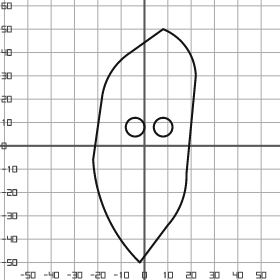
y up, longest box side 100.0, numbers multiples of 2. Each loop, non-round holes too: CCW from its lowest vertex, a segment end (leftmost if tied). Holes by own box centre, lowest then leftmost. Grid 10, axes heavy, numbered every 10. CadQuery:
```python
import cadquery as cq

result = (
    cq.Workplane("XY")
    .moveTo(-2.0, -50.0)
    .lineTo(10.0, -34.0)
    .threePointArc((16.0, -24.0), (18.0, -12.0))
    .lineTo(22.0, 30.0)
    .threePointArc((18.0, 42.0), (8.0, 50.0))
    .lineTo(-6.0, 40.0)
    .threePointArc((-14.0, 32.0), (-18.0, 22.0))
    .lineTo(-22.0, -6.0)
    .threePointArc((-16.0, -30.0), (-2.0, -50.0))
    .close()
    .moveTo(-4.0, 8.0)
    .circle(4.0)
    .moveTo(8.0, 8.0)
    .circle(4.0)
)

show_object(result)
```